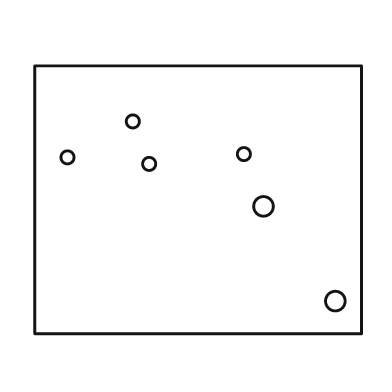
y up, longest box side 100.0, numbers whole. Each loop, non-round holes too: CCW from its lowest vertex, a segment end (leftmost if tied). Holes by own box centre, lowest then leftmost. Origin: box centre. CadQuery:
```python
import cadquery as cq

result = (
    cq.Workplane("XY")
    .moveTo(-50.0, -41.0)
    .lineTo(50.0, -41.0)
    .lineTo(50.0, 41.0)
    .lineTo(-50.0, 41.0)
    .close()
    .moveTo(42.0, -31.0)
    .circle(3.0)
    .moveTo(20.0, -2.0)
    .circle(3.0)
    .moveTo(-15.0, 11.0)
    .circle(2.0)
    .moveTo(-40.0, 13.0)
    .circle(2.0)
    .moveTo(14.0, 14.0)
    .circle(2.0)
    .moveTo(-20.0, 24.0)
    .circle(2.0)
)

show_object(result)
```